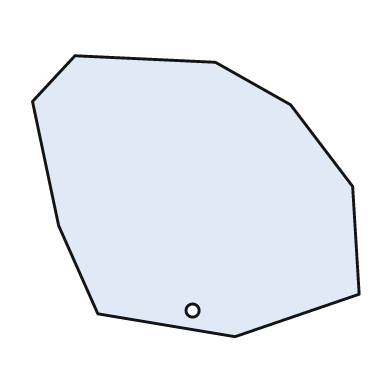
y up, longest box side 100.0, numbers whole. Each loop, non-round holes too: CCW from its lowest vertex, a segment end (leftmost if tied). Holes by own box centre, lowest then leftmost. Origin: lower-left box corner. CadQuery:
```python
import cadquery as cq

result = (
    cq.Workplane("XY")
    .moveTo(62.0, 0.0)
    .lineTo(100.0, 13.0)
    .lineTo(98.0, 46.0)
    .lineTo(79.0, 71.0)
    .lineTo(56.0, 84.0)
    .lineTo(13.0, 86.0)
    .lineTo(0.0, 72.0)
    .lineTo(8.0, 34.0)
    .lineTo(20.0, 7.0)
    .close()
    .moveTo(49.0, 8.0)
    .circle(2.0)
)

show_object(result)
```